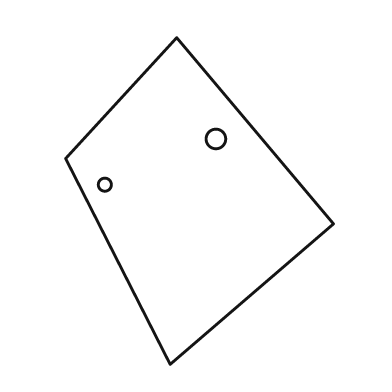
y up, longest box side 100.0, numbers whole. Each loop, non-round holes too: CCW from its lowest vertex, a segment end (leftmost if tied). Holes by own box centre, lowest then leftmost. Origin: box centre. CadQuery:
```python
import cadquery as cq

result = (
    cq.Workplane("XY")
    .moveTo(-9.0, -50.0)
    .lineTo(41.0, -7.0)
    .lineTo(-7.0, 50.0)
    .lineTo(-41.0, 13.0)
    .close()
    .moveTo(-29.0, 5.0)
    .circle(2.0)
    .moveTo(5.0, 19.0)
    .circle(3.0)
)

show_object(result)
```